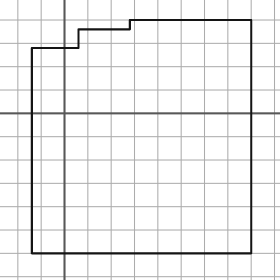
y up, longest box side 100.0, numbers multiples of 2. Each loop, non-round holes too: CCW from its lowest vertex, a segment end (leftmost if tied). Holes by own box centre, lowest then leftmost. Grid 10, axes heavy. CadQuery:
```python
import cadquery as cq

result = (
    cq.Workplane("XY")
    .moveTo(-14.0, -60.0)
    .lineTo(80.0, -60.0)
    .lineTo(80.0, 40.0)
    .lineTo(28.0, 40.0)
    .lineTo(28.0, 36.0)
    .lineTo(6.0, 36.0)
    .lineTo(6.0, 28.0)
    .lineTo(-14.0, 28.0)
    .close()
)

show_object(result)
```